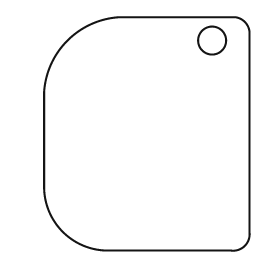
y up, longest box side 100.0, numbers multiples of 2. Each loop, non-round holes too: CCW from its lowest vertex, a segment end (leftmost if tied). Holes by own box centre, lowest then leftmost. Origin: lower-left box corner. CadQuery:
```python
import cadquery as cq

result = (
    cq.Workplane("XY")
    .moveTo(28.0, 0.0)
    .lineTo(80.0, 0.0)
    .threePointArc((86.0, 2.0), (88.0, 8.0))
    .lineTo(88.0, 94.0)
    .threePointArc((86.0, 98.0), (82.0, 100.0))
    .lineTo(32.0, 100.0)
    .threePointArc((10.0, 90.0), (0.0, 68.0))
    .lineTo(0.0, 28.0)
    .threePointArc((8.0, 8.0), (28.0, 0.0))
    .close()
    .moveTo(72.0, 90.0)
    .circle(6.0)
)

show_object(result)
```